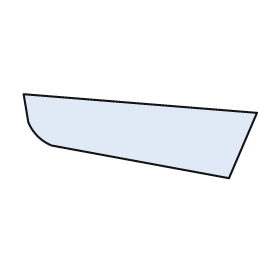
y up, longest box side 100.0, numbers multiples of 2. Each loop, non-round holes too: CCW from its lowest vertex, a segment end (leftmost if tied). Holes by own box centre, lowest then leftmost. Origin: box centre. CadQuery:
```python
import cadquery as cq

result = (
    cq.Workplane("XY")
    .moveTo(38.0, -18.0)
    .lineTo(50.0, 10.0)
    .lineTo(-50.0, 18.0)
    .lineTo(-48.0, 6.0)
    .threePointArc((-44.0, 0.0), (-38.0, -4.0))
    .close()
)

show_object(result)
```